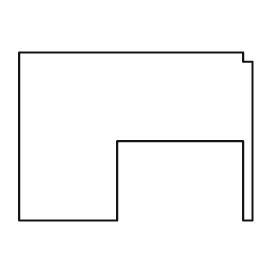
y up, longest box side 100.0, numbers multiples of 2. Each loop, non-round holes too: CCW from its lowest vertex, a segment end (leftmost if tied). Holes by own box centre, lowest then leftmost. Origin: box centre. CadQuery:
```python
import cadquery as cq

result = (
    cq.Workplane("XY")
    .moveTo(-50.0, -36.0)
    .lineTo(-8.0, -36.0)
    .lineTo(-8.0, -2.0)
    .lineTo(46.0, -2.0)
    .lineTo(46.0, -36.0)
    .lineTo(50.0, -36.0)
    .lineTo(50.0, 32.0)
    .lineTo(46.0, 32.0)
    .lineTo(46.0, 36.0)
    .lineTo(-50.0, 36.0)
    .close()
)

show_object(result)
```